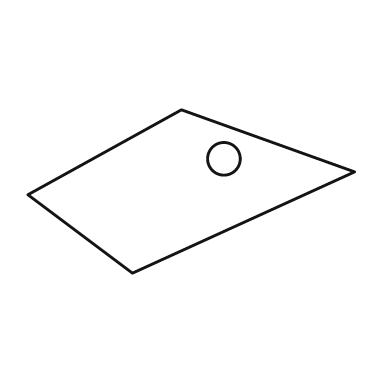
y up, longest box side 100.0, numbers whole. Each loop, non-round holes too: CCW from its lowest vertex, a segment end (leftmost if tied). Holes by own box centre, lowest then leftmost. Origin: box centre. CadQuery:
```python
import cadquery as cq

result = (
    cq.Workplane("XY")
    .moveTo(-18.0, -25.0)
    .lineTo(50.0, 6.0)
    .lineTo(-3.0, 25.0)
    .lineTo(-50.0, -1.0)
    .close()
    .moveTo(10.0, 10.0)
    .circle(5.0)
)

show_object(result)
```